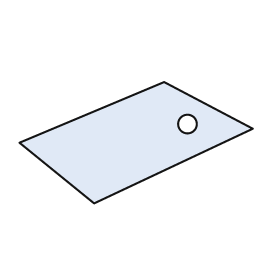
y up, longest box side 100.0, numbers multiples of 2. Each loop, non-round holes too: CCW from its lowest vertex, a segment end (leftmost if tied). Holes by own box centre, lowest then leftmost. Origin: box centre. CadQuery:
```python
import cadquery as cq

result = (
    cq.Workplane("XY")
    .moveTo(-18.0, -26.0)
    .lineTo(50.0, 6.0)
    .lineTo(12.0, 26.0)
    .lineTo(-50.0, 0.0)
    .close()
    .moveTo(22.0, 8.0)
    .circle(4.0)
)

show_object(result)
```